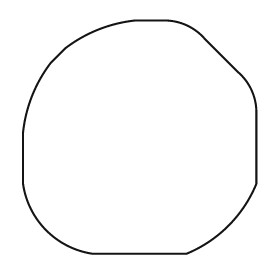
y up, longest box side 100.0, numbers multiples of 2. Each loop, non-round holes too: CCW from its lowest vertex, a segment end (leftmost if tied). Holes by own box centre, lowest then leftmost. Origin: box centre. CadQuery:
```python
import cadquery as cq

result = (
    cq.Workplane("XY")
    .moveTo(-20.0, -50.0)
    .lineTo(20.0, -50.0)
    .threePointArc((38.0, -38.0), (50.0, -20.0))
    .lineTo(50.0, 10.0)
    .threePointArc((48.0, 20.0), (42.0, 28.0))
    .lineTo(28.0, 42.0)
    .threePointArc((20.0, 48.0), (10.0, 50.0))
    .lineTo(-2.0, 50.0)
    .threePointArc((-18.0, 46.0), (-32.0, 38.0))
    .lineTo(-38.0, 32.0)
    .threePointArc((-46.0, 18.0), (-50.0, 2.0))
    .lineTo(-50.0, -20.0)
    .threePointArc((-40.0, -40.0), (-20.0, -50.0))
    .close()
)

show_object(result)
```